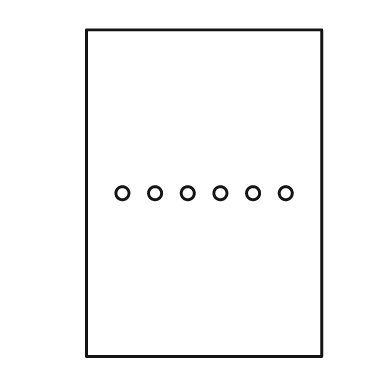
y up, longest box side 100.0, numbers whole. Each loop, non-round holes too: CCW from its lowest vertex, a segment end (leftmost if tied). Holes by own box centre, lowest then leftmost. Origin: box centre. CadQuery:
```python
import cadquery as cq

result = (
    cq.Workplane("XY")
    .moveTo(-36.0, -50.0)
    .lineTo(36.0, -50.0)
    .lineTo(36.0, 50.0)
    .lineTo(-36.0, 50.0)
    .close()
    .moveTo(-25.0, 0.0)
    .circle(2.0)
    .moveTo(-15.0, 0.0)
    .circle(2.0)
    .moveTo(-5.0, 0.0)
    .circle(2.0)
    .moveTo(5.0, 0.0)
    .circle(2.0)
    .moveTo(15.0, 0.0)
    .circle(2.0)
    .moveTo(25.0, 0.0)
    .circle(2.0)
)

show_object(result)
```